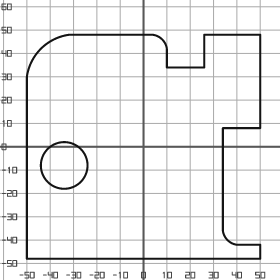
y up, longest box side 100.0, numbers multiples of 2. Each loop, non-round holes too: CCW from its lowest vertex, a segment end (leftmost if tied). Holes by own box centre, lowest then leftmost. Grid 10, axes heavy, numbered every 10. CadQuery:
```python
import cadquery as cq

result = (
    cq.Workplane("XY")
    .moveTo(-50.0, -48.0)
    .lineTo(50.0, -48.0)
    .lineTo(50.0, -42.0)
    .lineTo(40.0, -42.0)
    .threePointArc((36.0, -40.0), (34.0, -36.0))
    .lineTo(34.0, 8.0)
    .lineTo(50.0, 8.0)
    .lineTo(50.0, 48.0)
    .lineTo(26.0, 48.0)
    .lineTo(26.0, 34.0)
    .lineTo(10.0, 34.0)
    .lineTo(10.0, 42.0)
    .threePointArc((8.0, 46.0), (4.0, 48.0))
    .lineTo(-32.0, 48.0)
    .threePointArc((-44.0, 42.0), (-50.0, 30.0))
    .close()
    .moveTo(-34.0, -8.0)
    .circle(10.0)
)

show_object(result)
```